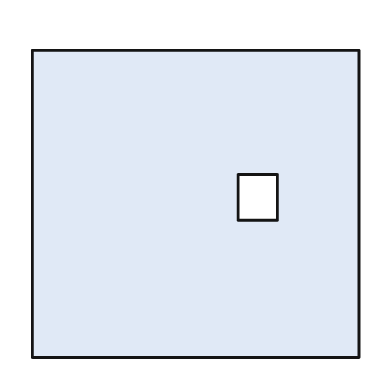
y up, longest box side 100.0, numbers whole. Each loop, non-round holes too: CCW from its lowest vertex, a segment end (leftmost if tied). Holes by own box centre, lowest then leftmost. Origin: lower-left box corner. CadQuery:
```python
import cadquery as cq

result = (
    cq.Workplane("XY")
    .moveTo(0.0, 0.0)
    .lineTo(100.0, 0.0)
    .lineTo(100.0, 94.0)
    .lineTo(0.0, 94.0)
    .close()
    .moveTo(63.0, 42.0)
    .lineTo(75.0, 42.0)
    .lineTo(75.0, 56.0)
    .lineTo(63.0, 56.0)
    .close()
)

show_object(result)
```